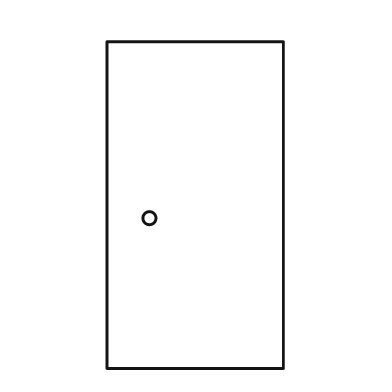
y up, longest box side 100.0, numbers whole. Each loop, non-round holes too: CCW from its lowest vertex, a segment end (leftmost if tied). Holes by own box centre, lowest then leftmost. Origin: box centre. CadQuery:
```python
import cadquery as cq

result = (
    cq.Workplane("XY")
    .moveTo(-27.0, -50.0)
    .lineTo(27.0, -50.0)
    .lineTo(27.0, 50.0)
    .lineTo(-27.0, 50.0)
    .close()
    .moveTo(-14.0, -4.0)
    .circle(2.0)
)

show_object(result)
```